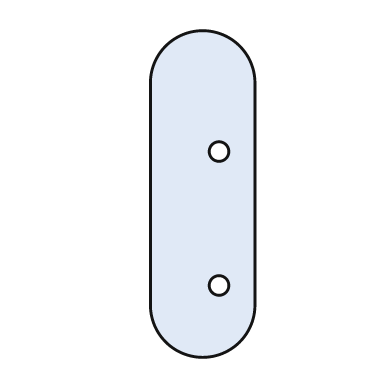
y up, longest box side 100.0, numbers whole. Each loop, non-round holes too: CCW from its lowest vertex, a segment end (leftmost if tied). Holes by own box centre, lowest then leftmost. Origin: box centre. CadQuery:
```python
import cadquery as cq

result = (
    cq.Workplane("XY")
    .moveTo(-16.0, -34.0)
    .threePointArc((0.0, -50.0), (16.0, -34.0))
    .lineTo(16.0, 34.0)
    .threePointArc((0.0, 50.0), (-16.0, 34.0))
    .close()
    .moveTo(5.0, -28.0)
    .circle(3.0)
    .moveTo(5.0, 13.0)
    .circle(3.0)
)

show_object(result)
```